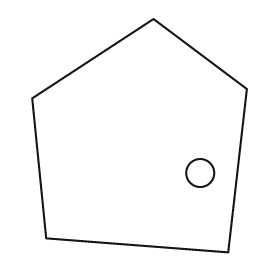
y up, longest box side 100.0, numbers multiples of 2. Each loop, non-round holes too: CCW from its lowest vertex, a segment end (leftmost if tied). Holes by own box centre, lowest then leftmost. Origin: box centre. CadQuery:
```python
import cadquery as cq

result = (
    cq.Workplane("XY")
    .moveTo(38.0, -50.0)
    .lineTo(46.0, 20.0)
    .lineTo(6.0, 50.0)
    .lineTo(-46.0, 16.0)
    .lineTo(-40.0, -44.0)
    .close()
    .moveTo(26.0, -16.0)
    .circle(6.0)
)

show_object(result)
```